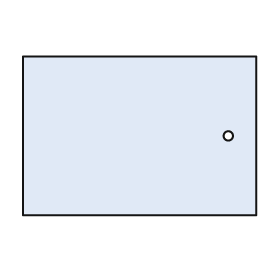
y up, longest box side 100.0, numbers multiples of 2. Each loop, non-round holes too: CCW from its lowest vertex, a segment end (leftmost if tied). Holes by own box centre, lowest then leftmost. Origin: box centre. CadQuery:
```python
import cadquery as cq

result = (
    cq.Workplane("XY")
    .moveTo(-50.0, -34.0)
    .lineTo(50.0, -34.0)
    .lineTo(50.0, 34.0)
    .lineTo(-50.0, 34.0)
    .close()
    .moveTo(38.0, 0.0)
    .circle(2.0)
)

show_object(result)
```